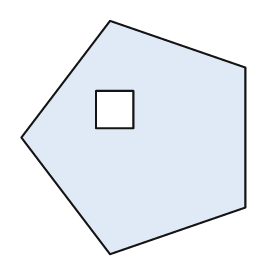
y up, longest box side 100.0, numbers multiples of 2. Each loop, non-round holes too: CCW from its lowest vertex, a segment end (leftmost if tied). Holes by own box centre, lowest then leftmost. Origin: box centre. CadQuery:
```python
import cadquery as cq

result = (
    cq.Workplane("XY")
    .moveTo(-10.0, -50.0)
    .lineTo(48.0, -30.0)
    .lineTo(48.0, 30.0)
    .lineTo(-10.0, 50.0)
    .lineTo(-48.0, 0.0)
    .close()
    .moveTo(-16.0, 4.0)
    .lineTo(0.0, 4.0)
    .lineTo(0.0, 20.0)
    .lineTo(-16.0, 20.0)
    .close()
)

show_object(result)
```